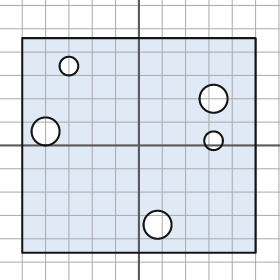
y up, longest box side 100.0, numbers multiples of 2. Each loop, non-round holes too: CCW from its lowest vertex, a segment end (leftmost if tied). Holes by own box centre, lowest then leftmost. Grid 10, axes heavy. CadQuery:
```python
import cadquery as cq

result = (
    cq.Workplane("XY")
    .moveTo(-50.0, -46.0)
    .lineTo(50.0, -46.0)
    .lineTo(50.0, 46.0)
    .lineTo(-50.0, 46.0)
    .close()
    .moveTo(8.0, -34.0)
    .circle(6.0)
    .moveTo(32.0, 2.0)
    .circle(4.0)
    .moveTo(-40.0, 6.0)
    .circle(6.0)
    .moveTo(32.0, 20.0)
    .circle(6.0)
    .moveTo(-30.0, 34.0)
    .circle(4.0)
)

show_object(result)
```